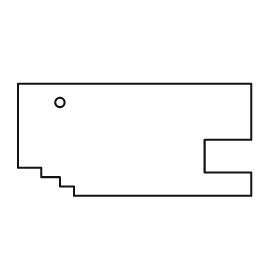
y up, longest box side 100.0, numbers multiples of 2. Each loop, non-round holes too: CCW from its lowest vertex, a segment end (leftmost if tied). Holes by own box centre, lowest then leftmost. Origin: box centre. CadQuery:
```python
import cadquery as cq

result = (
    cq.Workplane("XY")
    .moveTo(-26.0, -24.0)
    .lineTo(50.0, -24.0)
    .lineTo(50.0, -14.0)
    .lineTo(30.0, -14.0)
    .lineTo(30.0, 0.0)
    .lineTo(50.0, 0.0)
    .lineTo(50.0, 24.0)
    .lineTo(-50.0, 24.0)
    .lineTo(-50.0, -12.0)
    .lineTo(-40.0, -12.0)
    .lineTo(-40.0, -16.0)
    .lineTo(-32.0, -16.0)
    .lineTo(-32.0, -20.0)
    .lineTo(-26.0, -20.0)
    .close()
    .moveTo(-32.0, 16.0)
    .circle(2.0)
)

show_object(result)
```